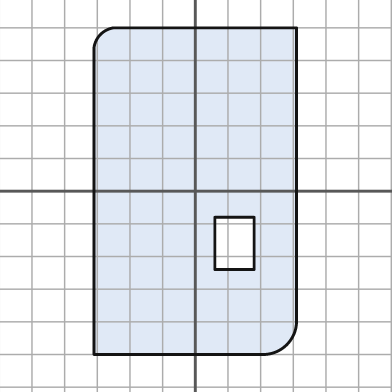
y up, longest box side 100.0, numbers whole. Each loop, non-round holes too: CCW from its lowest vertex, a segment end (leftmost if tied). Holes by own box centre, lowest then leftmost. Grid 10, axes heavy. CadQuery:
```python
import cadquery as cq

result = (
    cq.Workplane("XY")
    .moveTo(-31.0, -50.0)
    .lineTo(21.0, -50.0)
    .threePointArc((28.0, -47.0), (31.0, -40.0))
    .lineTo(31.0, 50.0)
    .lineTo(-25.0, 50.0)
    .threePointArc((-29.0, 48.0), (-31.0, 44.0))
    .close()
    .moveTo(6.0, -24.0)
    .lineTo(18.0, -24.0)
    .lineTo(18.0, -8.0)
    .lineTo(6.0, -8.0)
    .close()
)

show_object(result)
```